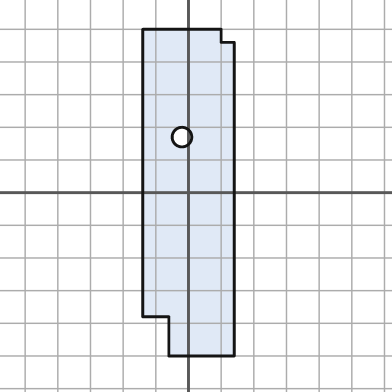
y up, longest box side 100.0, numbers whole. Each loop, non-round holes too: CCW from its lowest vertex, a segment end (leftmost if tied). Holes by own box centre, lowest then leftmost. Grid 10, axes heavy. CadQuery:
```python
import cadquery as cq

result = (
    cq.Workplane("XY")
    .moveTo(-6.0, -50.0)
    .lineTo(14.0, -50.0)
    .lineTo(14.0, 46.0)
    .lineTo(10.0, 46.0)
    .lineTo(10.0, 50.0)
    .lineTo(-14.0, 50.0)
    .lineTo(-14.0, -38.0)
    .lineTo(-6.0, -38.0)
    .close()
    .moveTo(-2.0, 17.0)
    .circle(3.0)
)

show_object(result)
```